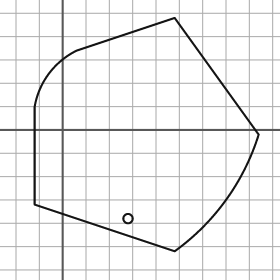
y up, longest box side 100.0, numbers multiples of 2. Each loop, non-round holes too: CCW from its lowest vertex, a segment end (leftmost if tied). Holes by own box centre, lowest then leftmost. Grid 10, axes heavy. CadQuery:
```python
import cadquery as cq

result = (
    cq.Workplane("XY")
    .moveTo(48.0, -52.0)
    .threePointArc((70.0, -30.0), (84.0, -2.0))
    .lineTo(48.0, 48.0)
    .lineTo(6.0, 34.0)
    .threePointArc((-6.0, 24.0), (-12.0, 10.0))
    .lineTo(-12.0, -32.0)
    .close()
    .moveTo(28.0, -38.0)
    .circle(2.0)
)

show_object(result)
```